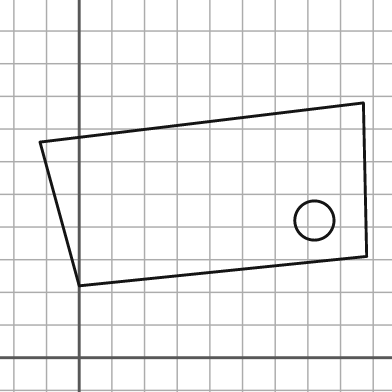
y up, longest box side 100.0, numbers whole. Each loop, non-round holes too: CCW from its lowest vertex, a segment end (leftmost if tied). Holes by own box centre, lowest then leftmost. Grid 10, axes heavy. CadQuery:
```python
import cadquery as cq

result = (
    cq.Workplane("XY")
    .moveTo(0.0, 22.0)
    .lineTo(88.0, 31.0)
    .lineTo(87.0, 78.0)
    .lineTo(-12.0, 66.0)
    .close()
    .moveTo(72.0, 42.0)
    .circle(6.0)
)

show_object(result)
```